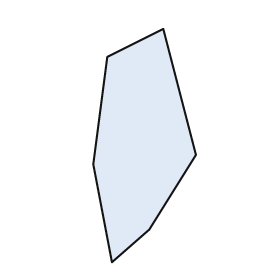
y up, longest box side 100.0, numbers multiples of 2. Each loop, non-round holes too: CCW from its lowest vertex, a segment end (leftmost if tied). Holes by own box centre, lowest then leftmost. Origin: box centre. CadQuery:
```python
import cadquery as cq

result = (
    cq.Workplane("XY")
    .moveTo(-14.0, -50.0)
    .lineTo(2.0, -36.0)
    .lineTo(22.0, -4.0)
    .lineTo(8.0, 50.0)
    .lineTo(-16.0, 38.0)
    .lineTo(-22.0, -8.0)
    .close()
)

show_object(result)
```